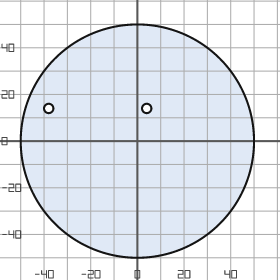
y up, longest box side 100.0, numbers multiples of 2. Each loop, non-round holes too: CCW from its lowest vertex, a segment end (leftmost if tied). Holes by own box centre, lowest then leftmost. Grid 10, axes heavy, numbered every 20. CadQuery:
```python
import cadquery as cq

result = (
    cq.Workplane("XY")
    .moveTo(0.0, 0.0)
    .circle(50.0)
    .moveTo(-38.0, 14.0)
    .circle(2.0)
    .moveTo(4.0, 14.0)
    .circle(2.0)
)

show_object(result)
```